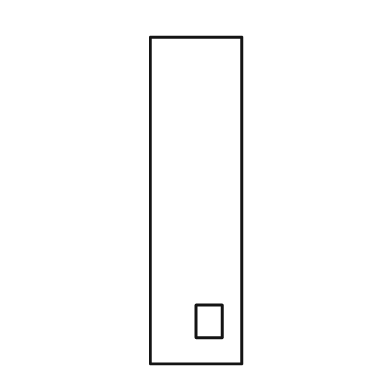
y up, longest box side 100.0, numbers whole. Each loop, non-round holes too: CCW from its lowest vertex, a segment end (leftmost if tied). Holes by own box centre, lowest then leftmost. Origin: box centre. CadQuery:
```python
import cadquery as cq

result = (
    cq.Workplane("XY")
    .moveTo(-14.0, -50.0)
    .lineTo(14.0, -50.0)
    .lineTo(14.0, 50.0)
    .lineTo(-14.0, 50.0)
    .close()
    .moveTo(0.0, -42.0)
    .lineTo(8.0, -42.0)
    .lineTo(8.0, -32.0)
    .lineTo(0.0, -32.0)
    .close()
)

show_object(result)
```